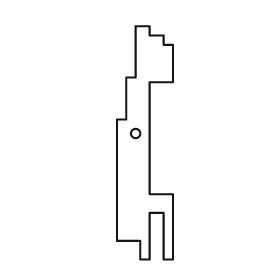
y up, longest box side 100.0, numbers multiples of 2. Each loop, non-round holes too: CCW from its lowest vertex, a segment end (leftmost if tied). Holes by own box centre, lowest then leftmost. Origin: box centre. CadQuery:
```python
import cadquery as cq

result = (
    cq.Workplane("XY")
    .moveTo(-2.0, -50.0)
    .lineTo(2.0, -50.0)
    .lineTo(2.0, -30.0)
    .lineTo(8.0, -30.0)
    .lineTo(8.0, -50.0)
    .lineTo(12.0, -50.0)
    .lineTo(12.0, -22.0)
    .lineTo(2.0, -22.0)
    .lineTo(2.0, 26.0)
    .lineTo(12.0, 26.0)
    .lineTo(12.0, 42.0)
    .lineTo(8.0, 42.0)
    .lineTo(8.0, 46.0)
    .lineTo(2.0, 46.0)
    .lineTo(2.0, 50.0)
    .lineTo(-4.0, 50.0)
    .lineTo(-4.0, 28.0)
    .lineTo(-8.0, 28.0)
    .lineTo(-8.0, 10.0)
    .lineTo(-12.0, 10.0)
    .lineTo(-12.0, -42.0)
    .lineTo(-2.0, -42.0)
    .close()
    .moveTo(-4.0, 4.0)
    .circle(2.0)
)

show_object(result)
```